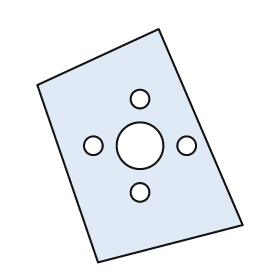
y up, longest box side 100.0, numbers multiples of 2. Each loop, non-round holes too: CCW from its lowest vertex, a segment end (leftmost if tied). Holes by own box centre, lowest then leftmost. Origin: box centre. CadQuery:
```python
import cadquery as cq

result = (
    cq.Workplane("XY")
    .moveTo(-18.0, -50.0)
    .lineTo(44.0, -34.0)
    .lineTo(8.0, 50.0)
    .lineTo(-44.0, 26.0)
    .close()
    .moveTo(0.0, -20.0)
    .circle(4.0)
    .moveTo(-20.0, 0.0)
    .circle(4.0)
    .moveTo(0.0, 0.0)
    .circle(10.0)
    .moveTo(20.0, 0.0)
    .circle(4.0)
    .moveTo(0.0, 20.0)
    .circle(4.0)
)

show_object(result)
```